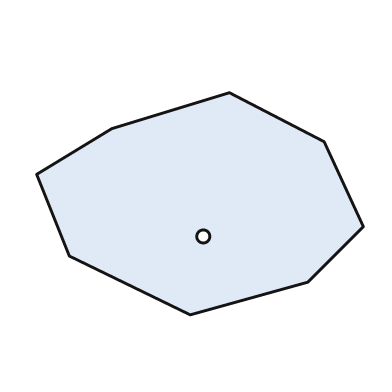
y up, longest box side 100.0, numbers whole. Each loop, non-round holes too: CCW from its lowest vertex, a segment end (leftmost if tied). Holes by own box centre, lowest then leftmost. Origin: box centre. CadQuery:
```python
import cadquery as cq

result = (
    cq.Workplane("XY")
    .moveTo(-3.0, -34.0)
    .lineTo(33.0, -24.0)
    .lineTo(50.0, -7.0)
    .lineTo(38.0, 19.0)
    .lineTo(9.0, 34.0)
    .lineTo(-27.0, 23.0)
    .lineTo(-50.0, 9.0)
    .lineTo(-40.0, -16.0)
    .close()
    .moveTo(1.0, -10.0)
    .circle(2.0)
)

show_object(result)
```